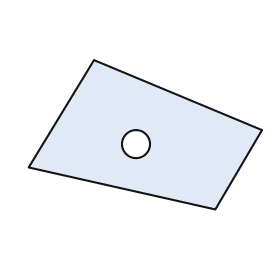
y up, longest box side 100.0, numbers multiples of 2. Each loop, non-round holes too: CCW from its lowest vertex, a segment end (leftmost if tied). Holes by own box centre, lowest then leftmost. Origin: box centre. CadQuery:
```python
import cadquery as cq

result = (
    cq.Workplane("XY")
    .moveTo(30.0, -32.0)
    .lineTo(50.0, 2.0)
    .lineTo(-22.0, 32.0)
    .lineTo(-50.0, -14.0)
    .close()
    .moveTo(-4.0, -4.0)
    .circle(6.0)
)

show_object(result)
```